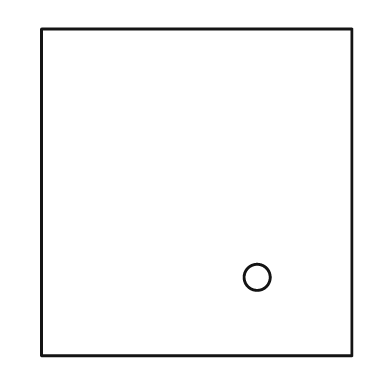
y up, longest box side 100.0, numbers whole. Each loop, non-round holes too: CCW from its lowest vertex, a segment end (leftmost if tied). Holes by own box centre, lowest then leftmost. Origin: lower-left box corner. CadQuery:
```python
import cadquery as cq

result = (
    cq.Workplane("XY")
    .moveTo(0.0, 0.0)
    .lineTo(95.0, 0.0)
    .lineTo(95.0, 100.0)
    .lineTo(0.0, 100.0)
    .close()
    .moveTo(66.0, 24.0)
    .circle(4.0)
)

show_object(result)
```